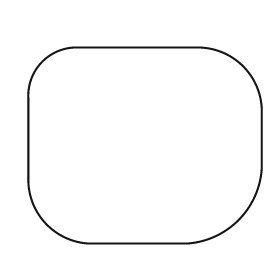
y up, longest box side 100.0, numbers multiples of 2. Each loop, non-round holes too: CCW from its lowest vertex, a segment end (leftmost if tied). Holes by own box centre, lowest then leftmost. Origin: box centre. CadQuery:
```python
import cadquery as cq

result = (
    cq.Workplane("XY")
    .moveTo(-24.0, -42.0)
    .lineTo(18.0, -42.0)
    .threePointArc((40.0, -32.0), (50.0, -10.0))
    .lineTo(50.0, 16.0)
    .threePointArc((42.0, 34.0), (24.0, 42.0))
    .lineTo(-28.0, 42.0)
    .threePointArc((-44.0, 36.0), (-50.0, 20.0))
    .lineTo(-50.0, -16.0)
    .threePointArc((-42.0, -34.0), (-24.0, -42.0))
    .close()
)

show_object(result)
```